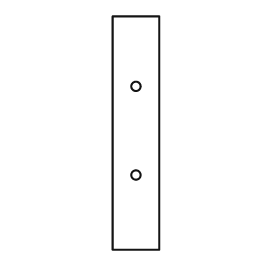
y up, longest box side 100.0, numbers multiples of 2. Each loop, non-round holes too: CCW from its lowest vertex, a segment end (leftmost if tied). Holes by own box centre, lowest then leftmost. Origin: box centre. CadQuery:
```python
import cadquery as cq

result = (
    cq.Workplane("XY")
    .moveTo(-10.0, -50.0)
    .lineTo(10.0, -50.0)
    .lineTo(10.0, 50.0)
    .lineTo(-10.0, 50.0)
    .close()
    .moveTo(0.0, -18.0)
    .circle(2.0)
    .moveTo(0.0, 20.0)
    .circle(2.0)
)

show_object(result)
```